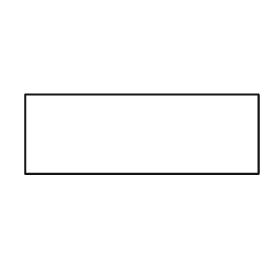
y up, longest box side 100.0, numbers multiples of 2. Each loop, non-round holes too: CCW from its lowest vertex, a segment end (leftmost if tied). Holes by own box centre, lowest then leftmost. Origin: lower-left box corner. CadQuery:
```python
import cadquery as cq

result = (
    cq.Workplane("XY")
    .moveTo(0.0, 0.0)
    .lineTo(100.0, 0.0)
    .lineTo(100.0, 34.0)
    .lineTo(0.0, 34.0)
    .close()
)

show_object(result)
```